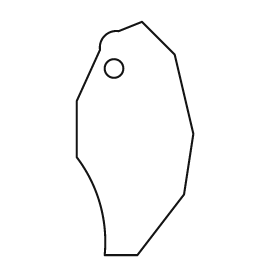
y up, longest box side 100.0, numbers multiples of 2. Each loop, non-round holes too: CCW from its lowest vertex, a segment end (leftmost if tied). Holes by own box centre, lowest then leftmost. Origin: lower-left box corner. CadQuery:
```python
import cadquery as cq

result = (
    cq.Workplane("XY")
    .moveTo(12.0, 0.0)
    .lineTo(26.0, 0.0)
    .lineTo(46.0, 26.0)
    .lineTo(50.0, 52.0)
    .lineTo(42.0, 86.0)
    .lineTo(28.0, 100.0)
    .lineTo(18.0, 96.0)
    .threePointArc((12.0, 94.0), (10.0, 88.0))
    .lineTo(0.0, 66.0)
    .lineTo(0.0, 42.0)
    .threePointArc((10.0, 22.0), (12.0, 0.0))
    .close()
    .moveTo(16.0, 80.0)
    .circle(4.0)
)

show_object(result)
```